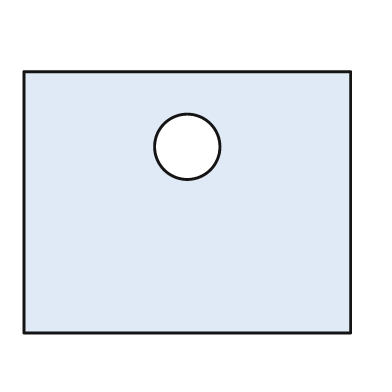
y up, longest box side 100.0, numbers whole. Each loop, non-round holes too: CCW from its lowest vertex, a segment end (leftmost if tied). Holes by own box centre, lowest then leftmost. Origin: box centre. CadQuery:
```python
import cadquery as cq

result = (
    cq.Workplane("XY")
    .moveTo(-50.0, -40.0)
    .lineTo(50.0, -40.0)
    .lineTo(50.0, 40.0)
    .lineTo(-50.0, 40.0)
    .close()
    .moveTo(0.0, 17.0)
    .circle(10.0)
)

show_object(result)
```